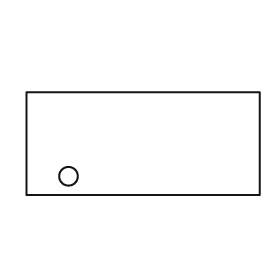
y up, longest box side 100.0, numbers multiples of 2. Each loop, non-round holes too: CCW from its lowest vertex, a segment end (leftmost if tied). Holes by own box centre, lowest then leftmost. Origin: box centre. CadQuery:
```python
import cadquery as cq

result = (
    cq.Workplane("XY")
    .moveTo(-50.0, -22.0)
    .lineTo(50.0, -22.0)
    .lineTo(50.0, 22.0)
    .lineTo(-50.0, 22.0)
    .close()
    .moveTo(-32.0, -14.0)
    .circle(4.0)
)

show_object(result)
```